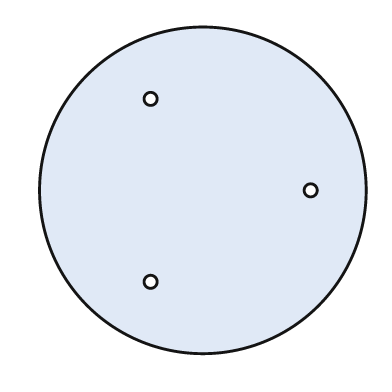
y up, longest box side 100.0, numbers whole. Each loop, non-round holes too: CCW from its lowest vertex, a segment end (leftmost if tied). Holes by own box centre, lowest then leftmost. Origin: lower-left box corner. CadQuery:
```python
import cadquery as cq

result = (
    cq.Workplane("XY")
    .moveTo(50.0, 50.0)
    .circle(50.0)
    .moveTo(34.0, 22.0)
    .circle(2.0)
    .moveTo(83.0, 50.0)
    .circle(2.0)
    .moveTo(34.0, 78.0)
    .circle(2.0)
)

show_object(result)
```